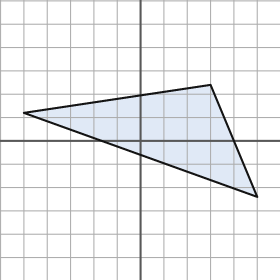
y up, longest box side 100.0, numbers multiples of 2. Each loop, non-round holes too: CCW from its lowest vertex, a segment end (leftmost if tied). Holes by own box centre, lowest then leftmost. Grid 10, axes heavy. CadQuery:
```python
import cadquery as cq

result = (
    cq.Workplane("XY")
    .moveTo(50.0, -24.0)
    .lineTo(30.0, 24.0)
    .lineTo(-50.0, 12.0)
    .close()
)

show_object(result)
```